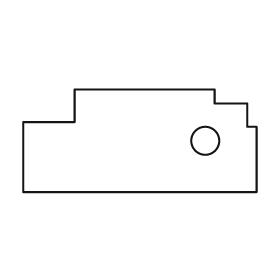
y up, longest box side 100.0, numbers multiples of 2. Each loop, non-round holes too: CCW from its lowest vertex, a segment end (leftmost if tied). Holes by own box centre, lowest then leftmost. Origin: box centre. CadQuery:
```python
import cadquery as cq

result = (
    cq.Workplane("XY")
    .moveTo(-50.0, -22.0)
    .lineTo(50.0, -22.0)
    .lineTo(50.0, 6.0)
    .lineTo(46.0, 6.0)
    .lineTo(46.0, 16.0)
    .lineTo(32.0, 16.0)
    .lineTo(32.0, 22.0)
    .lineTo(-28.0, 22.0)
    .lineTo(-28.0, 8.0)
    .lineTo(-50.0, 8.0)
    .close()
    .moveTo(28.0, 0.0)
    .circle(6.0)
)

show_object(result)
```